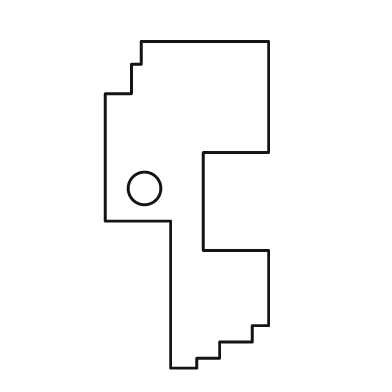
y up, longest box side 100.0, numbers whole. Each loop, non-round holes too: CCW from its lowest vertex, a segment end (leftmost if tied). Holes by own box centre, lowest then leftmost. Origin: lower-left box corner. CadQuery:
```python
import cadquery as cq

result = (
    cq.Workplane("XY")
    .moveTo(20.0, 0.0)
    .lineTo(28.0, 0.0)
    .lineTo(28.0, 3.0)
    .lineTo(35.0, 3.0)
    .lineTo(35.0, 8.0)
    .lineTo(45.0, 8.0)
    .lineTo(45.0, 13.0)
    .lineTo(50.0, 13.0)
    .lineTo(50.0, 36.0)
    .lineTo(30.0, 36.0)
    .lineTo(30.0, 66.0)
    .lineTo(50.0, 66.0)
    .lineTo(50.0, 100.0)
    .lineTo(11.0, 100.0)
    .lineTo(11.0, 93.0)
    .lineTo(8.0, 93.0)
    .lineTo(8.0, 84.0)
    .lineTo(0.0, 84.0)
    .lineTo(0.0, 45.0)
    .lineTo(20.0, 45.0)
    .close()
    .moveTo(12.0, 55.0)
    .circle(5.0)
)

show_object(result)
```